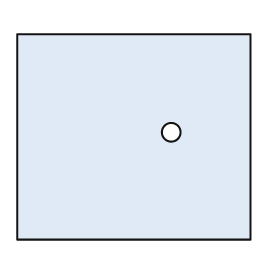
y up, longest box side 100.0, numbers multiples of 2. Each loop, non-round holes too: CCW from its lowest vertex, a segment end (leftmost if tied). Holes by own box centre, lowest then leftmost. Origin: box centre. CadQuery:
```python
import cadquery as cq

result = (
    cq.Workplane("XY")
    .moveTo(-50.0, -44.0)
    .lineTo(50.0, -44.0)
    .lineTo(50.0, 44.0)
    .lineTo(-50.0, 44.0)
    .close()
    .moveTo(16.0, 2.0)
    .circle(4.0)
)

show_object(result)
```